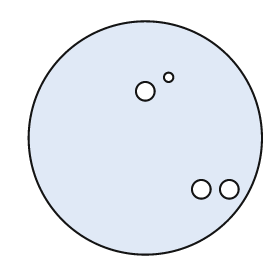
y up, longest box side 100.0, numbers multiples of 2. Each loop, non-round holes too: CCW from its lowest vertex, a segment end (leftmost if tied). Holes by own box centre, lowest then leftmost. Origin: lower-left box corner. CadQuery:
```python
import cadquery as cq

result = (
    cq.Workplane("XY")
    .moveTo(50.0, 50.0)
    .circle(50.0)
    .moveTo(74.0, 28.0)
    .circle(4.0)
    .moveTo(86.0, 28.0)
    .circle(4.0)
    .moveTo(50.0, 70.0)
    .circle(4.0)
    .moveTo(60.0, 76.0)
    .circle(2.0)
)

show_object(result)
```